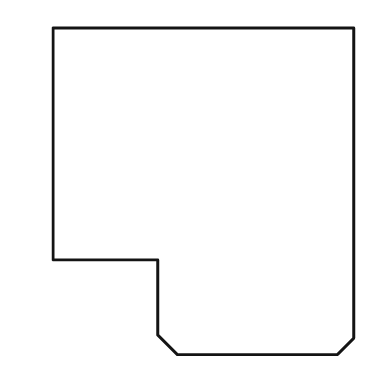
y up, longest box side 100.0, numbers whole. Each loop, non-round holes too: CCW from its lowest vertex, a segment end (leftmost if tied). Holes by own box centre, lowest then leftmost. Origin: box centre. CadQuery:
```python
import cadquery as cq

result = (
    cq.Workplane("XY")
    .moveTo(-8.0, -50.0)
    .lineTo(41.0, -50.0)
    .lineTo(46.0, -45.0)
    .lineTo(46.0, 50.0)
    .lineTo(-46.0, 50.0)
    .lineTo(-46.0, -21.0)
    .lineTo(-14.0, -21.0)
    .lineTo(-14.0, -44.0)
    .close()
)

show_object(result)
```